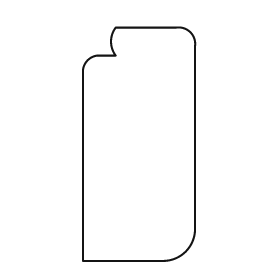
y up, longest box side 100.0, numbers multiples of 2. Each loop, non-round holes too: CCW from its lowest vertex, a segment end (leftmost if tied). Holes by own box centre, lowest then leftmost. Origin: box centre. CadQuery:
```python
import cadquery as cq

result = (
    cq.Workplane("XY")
    .moveTo(-24.0, -50.0)
    .lineTo(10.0, -50.0)
    .threePointArc((20.0, -46.0), (24.0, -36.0))
    .lineTo(24.0, 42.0)
    .threePointArc((22.0, 48.0), (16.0, 50.0))
    .lineTo(-10.0, 50.0)
    .threePointArc((-12.0, 44.0), (-10.0, 38.0))
    .lineTo(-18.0, 38.0)
    .threePointArc((-22.0, 36.0), (-24.0, 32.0))
    .close()
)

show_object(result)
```